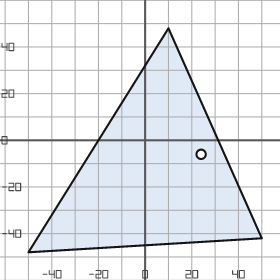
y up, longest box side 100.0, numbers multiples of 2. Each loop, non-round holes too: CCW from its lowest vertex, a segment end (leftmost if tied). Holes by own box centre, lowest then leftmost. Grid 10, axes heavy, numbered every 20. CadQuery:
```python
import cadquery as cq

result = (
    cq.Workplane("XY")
    .moveTo(-50.0, -48.0)
    .lineTo(50.0, -42.0)
    .lineTo(10.0, 48.0)
    .close()
    .moveTo(24.0, -6.0)
    .circle(2.0)
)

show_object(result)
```